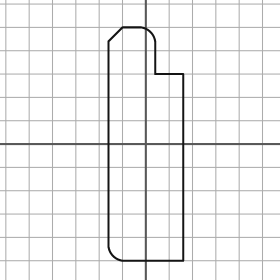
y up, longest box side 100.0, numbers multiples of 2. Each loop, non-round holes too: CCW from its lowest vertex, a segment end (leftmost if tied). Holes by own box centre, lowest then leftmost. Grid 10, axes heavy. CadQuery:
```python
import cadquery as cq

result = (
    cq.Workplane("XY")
    .moveTo(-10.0, -50.0)
    .lineTo(16.0, -50.0)
    .lineTo(16.0, 30.0)
    .lineTo(4.0, 30.0)
    .lineTo(4.0, 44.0)
    .threePointArc((2.0, 48.0), (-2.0, 50.0))
    .lineTo(-10.0, 50.0)
    .lineTo(-16.0, 44.0)
    .lineTo(-16.0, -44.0)
    .threePointArc((-14.0, -48.0), (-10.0, -50.0))
    .close()
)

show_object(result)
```